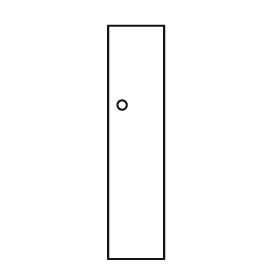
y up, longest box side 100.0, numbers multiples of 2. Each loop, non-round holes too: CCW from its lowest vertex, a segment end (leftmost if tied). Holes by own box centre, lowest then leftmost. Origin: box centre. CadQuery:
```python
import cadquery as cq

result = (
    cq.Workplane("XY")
    .moveTo(-12.0, -50.0)
    .lineTo(12.0, -50.0)
    .lineTo(12.0, 50.0)
    .lineTo(-12.0, 50.0)
    .close()
    .moveTo(-6.0, 16.0)
    .circle(2.0)
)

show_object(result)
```